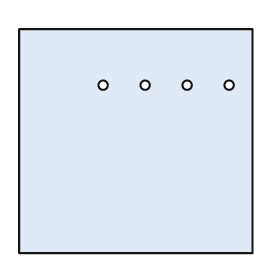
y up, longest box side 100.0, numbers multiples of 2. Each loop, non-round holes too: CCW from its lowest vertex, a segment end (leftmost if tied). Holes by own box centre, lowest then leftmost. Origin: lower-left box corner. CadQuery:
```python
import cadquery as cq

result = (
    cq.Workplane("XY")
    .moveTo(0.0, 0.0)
    .lineTo(100.0, 0.0)
    .lineTo(100.0, 96.0)
    .lineTo(0.0, 96.0)
    .close()
    .moveTo(36.0, 72.0)
    .circle(2.0)
    .moveTo(54.0, 72.0)
    .circle(2.0)
    .moveTo(72.0, 72.0)
    .circle(2.0)
    .moveTo(90.0, 72.0)
    .circle(2.0)
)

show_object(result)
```